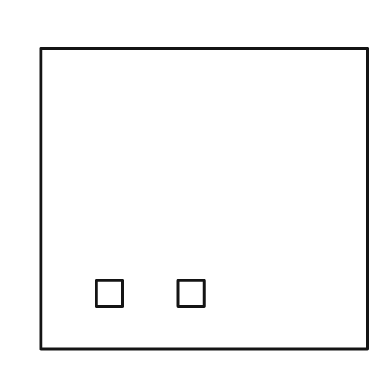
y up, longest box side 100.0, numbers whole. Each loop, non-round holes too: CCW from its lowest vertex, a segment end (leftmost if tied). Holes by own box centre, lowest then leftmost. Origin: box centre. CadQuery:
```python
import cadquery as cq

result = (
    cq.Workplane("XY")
    .moveTo(-50.0, -46.0)
    .lineTo(50.0, -46.0)
    .lineTo(50.0, 46.0)
    .lineTo(-50.0, 46.0)
    .close()
    .moveTo(-33.0, -33.0)
    .lineTo(-25.0, -33.0)
    .lineTo(-25.0, -25.0)
    .lineTo(-33.0, -25.0)
    .close()
    .moveTo(-8.0, -33.0)
    .lineTo(0.0, -33.0)
    .lineTo(0.0, -25.0)
    .lineTo(-8.0, -25.0)
    .close()
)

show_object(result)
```